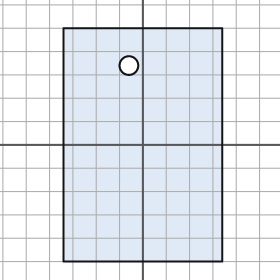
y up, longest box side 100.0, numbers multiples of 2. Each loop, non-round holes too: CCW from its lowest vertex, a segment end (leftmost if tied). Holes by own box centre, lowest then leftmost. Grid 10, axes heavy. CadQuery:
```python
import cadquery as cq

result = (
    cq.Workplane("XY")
    .moveTo(-34.0, -50.0)
    .lineTo(34.0, -50.0)
    .lineTo(34.0, 50.0)
    .lineTo(-34.0, 50.0)
    .close()
    .moveTo(-6.0, 34.0)
    .circle(4.0)
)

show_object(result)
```